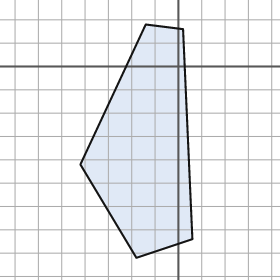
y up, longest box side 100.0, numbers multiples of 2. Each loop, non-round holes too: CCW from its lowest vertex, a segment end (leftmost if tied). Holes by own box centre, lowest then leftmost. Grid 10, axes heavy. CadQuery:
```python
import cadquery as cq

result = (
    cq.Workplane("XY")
    .moveTo(-18.0, -82.0)
    .lineTo(6.0, -74.0)
    .lineTo(2.0, 16.0)
    .lineTo(-14.0, 18.0)
    .lineTo(-42.0, -42.0)
    .close()
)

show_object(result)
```